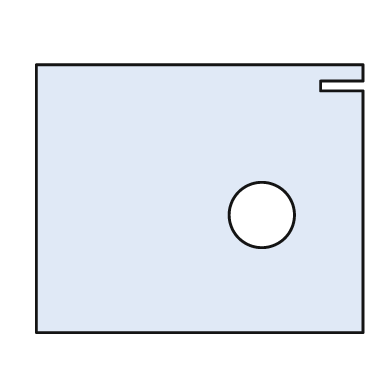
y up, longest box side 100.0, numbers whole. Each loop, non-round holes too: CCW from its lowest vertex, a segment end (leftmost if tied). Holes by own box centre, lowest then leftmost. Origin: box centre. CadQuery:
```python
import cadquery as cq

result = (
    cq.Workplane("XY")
    .moveTo(-50.0, -41.0)
    .lineTo(50.0, -41.0)
    .lineTo(50.0, 33.0)
    .lineTo(37.0, 33.0)
    .lineTo(37.0, 36.0)
    .lineTo(50.0, 36.0)
    .lineTo(50.0, 41.0)
    .lineTo(-50.0, 41.0)
    .close()
    .moveTo(19.0, -5.0)
    .circle(10.0)
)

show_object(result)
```